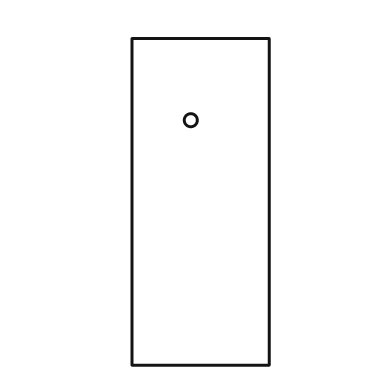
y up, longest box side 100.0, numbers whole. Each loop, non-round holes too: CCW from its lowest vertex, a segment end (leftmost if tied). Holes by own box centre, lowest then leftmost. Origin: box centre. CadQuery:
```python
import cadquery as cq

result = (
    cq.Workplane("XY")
    .moveTo(-21.0, -50.0)
    .lineTo(21.0, -50.0)
    .lineTo(21.0, 50.0)
    .lineTo(-21.0, 50.0)
    .close()
    .moveTo(-3.0, 25.0)
    .circle(2.0)
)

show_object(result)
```